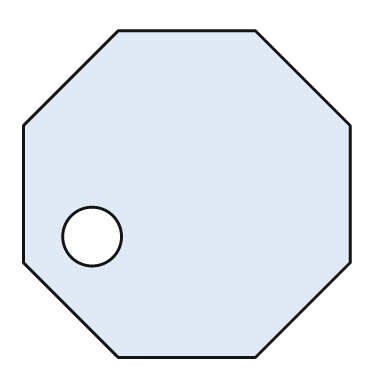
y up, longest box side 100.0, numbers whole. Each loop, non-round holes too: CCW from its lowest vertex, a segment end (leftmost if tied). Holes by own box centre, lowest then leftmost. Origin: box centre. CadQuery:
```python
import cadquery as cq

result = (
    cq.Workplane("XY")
    .moveTo(-21.0, -50.0)
    .lineTo(21.0, -50.0)
    .lineTo(50.0, -21.0)
    .lineTo(50.0, 21.0)
    .lineTo(21.0, 50.0)
    .lineTo(-21.0, 50.0)
    .lineTo(-50.0, 21.0)
    .lineTo(-50.0, -21.0)
    .close()
    .moveTo(-29.0, -13.0)
    .circle(9.0)
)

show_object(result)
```